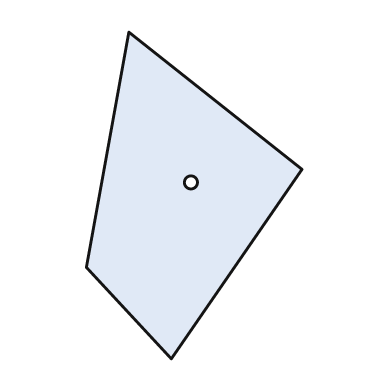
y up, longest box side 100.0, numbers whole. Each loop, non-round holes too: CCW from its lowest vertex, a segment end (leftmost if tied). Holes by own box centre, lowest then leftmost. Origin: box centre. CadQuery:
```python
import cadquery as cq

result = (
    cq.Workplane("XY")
    .moveTo(-7.0, -50.0)
    .lineTo(33.0, 8.0)
    .lineTo(-20.0, 50.0)
    .lineTo(-33.0, -22.0)
    .close()
    .moveTo(-1.0, 4.0)
    .circle(2.0)
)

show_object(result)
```